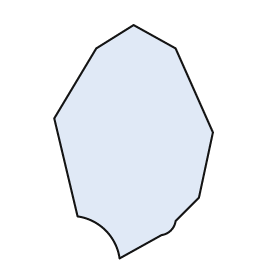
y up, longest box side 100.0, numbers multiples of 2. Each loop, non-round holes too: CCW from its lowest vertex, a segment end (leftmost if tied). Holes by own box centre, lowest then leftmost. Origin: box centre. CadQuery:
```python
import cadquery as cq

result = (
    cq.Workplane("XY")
    .moveTo(-6.0, -50.0)
    .lineTo(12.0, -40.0)
    .threePointArc((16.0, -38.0), (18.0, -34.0))
    .lineTo(28.0, -24.0)
    .lineTo(34.0, 4.0)
    .lineTo(18.0, 40.0)
    .lineTo(0.0, 50.0)
    .lineTo(-16.0, 40.0)
    .lineTo(-34.0, 10.0)
    .lineTo(-24.0, -32.0)
    .threePointArc((-12.0, -38.0), (-6.0, -50.0))
    .close()
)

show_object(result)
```